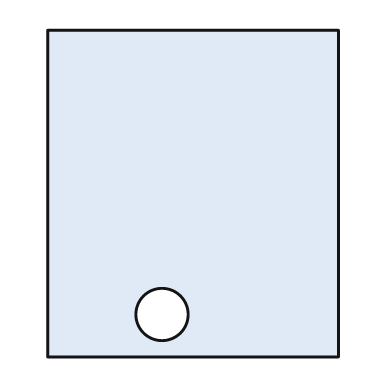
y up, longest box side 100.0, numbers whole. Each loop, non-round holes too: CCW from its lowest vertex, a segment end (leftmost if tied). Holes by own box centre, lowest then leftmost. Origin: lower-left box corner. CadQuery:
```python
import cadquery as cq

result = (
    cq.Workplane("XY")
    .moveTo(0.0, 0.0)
    .lineTo(89.0, 0.0)
    .lineTo(89.0, 100.0)
    .lineTo(0.0, 100.0)
    .close()
    .moveTo(35.0, 13.0)
    .circle(8.0)
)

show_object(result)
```